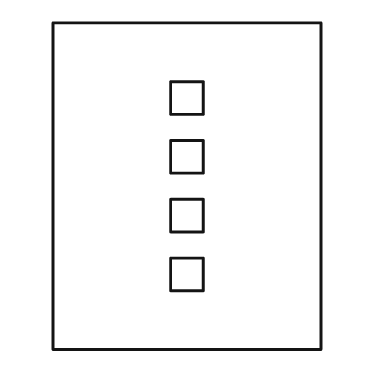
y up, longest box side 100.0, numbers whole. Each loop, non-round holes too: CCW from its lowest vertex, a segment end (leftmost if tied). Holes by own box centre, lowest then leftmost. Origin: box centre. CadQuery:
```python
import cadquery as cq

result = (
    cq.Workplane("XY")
    .moveTo(-41.0, -50.0)
    .lineTo(41.0, -50.0)
    .lineTo(41.0, 50.0)
    .lineTo(-41.0, 50.0)
    .close()
    .moveTo(-5.0, -32.0)
    .lineTo(5.0, -32.0)
    .lineTo(5.0, -22.0)
    .lineTo(-5.0, -22.0)
    .close()
    .moveTo(-5.0, -14.0)
    .lineTo(5.0, -14.0)
    .lineTo(5.0, -4.0)
    .lineTo(-5.0, -4.0)
    .close()
    .moveTo(-5.0, 4.0)
    .lineTo(5.0, 4.0)
    .lineTo(5.0, 14.0)
    .lineTo(-5.0, 14.0)
    .close()
    .moveTo(-5.0, 22.0)
    .lineTo(5.0, 22.0)
    .lineTo(5.0, 32.0)
    .lineTo(-5.0, 32.0)
    .close()
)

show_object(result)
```